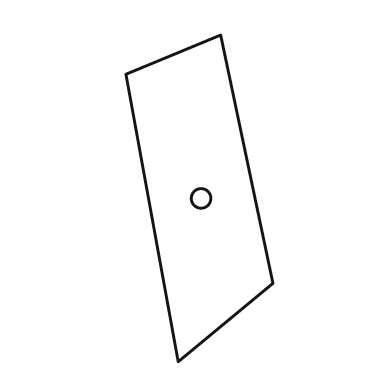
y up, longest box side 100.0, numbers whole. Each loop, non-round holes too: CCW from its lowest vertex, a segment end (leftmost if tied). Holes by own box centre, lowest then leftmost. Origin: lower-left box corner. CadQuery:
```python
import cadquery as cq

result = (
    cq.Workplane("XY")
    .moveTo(16.0, 0.0)
    .lineTo(45.0, 24.0)
    .lineTo(29.0, 100.0)
    .lineTo(0.0, 88.0)
    .close()
    .moveTo(23.0, 50.0)
    .circle(3.0)
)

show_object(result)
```